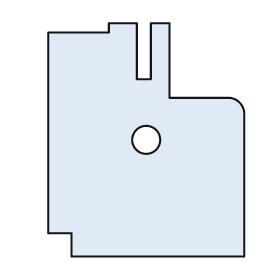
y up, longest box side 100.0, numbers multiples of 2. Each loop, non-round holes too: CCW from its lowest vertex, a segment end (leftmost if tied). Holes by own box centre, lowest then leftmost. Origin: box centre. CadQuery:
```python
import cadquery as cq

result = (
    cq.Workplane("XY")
    .moveTo(-32.0, -50.0)
    .lineTo(42.0, -50.0)
    .lineTo(42.0, 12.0)
    .threePointArc((40.0, 16.0), (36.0, 18.0))
    .lineTo(10.0, 18.0)
    .lineTo(10.0, 50.0)
    .lineTo(2.0, 50.0)
    .lineTo(2.0, 26.0)
    .lineTo(-4.0, 26.0)
    .lineTo(-4.0, 50.0)
    .lineTo(-16.0, 50.0)
    .lineTo(-16.0, 46.0)
    .lineTo(-42.0, 46.0)
    .lineTo(-42.0, -40.0)
    .lineTo(-32.0, -40.0)
    .close()
    .moveTo(0.0, 0.0)
    .circle(6.0)
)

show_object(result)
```